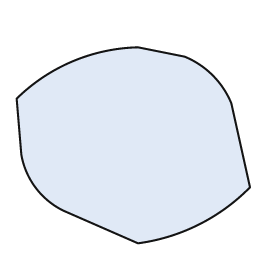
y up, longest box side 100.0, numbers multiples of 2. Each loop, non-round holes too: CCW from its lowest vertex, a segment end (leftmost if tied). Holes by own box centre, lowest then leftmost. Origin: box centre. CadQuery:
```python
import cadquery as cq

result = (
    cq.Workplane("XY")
    .moveTo(2.0, -42.0)
    .threePointArc((28.0, -34.0), (50.0, -18.0))
    .lineTo(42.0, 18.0)
    .threePointArc((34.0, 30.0), (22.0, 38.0))
    .lineTo(2.0, 42.0)
    .threePointArc((-26.0, 36.0), (-50.0, 20.0))
    .lineTo(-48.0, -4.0)
    .threePointArc((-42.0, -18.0), (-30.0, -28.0))
    .close()
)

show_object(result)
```